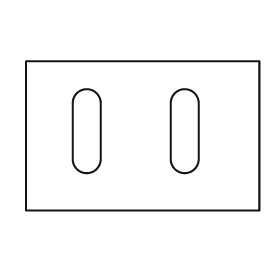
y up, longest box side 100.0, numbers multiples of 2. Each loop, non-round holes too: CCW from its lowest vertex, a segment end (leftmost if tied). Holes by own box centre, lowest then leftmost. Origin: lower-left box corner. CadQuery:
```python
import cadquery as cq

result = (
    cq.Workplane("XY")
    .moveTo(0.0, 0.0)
    .lineTo(100.0, 0.0)
    .lineTo(100.0, 64.0)
    .lineTo(0.0, 64.0)
    .close()
    .moveTo(20.0, 22.0)
    .threePointArc((26.0, 16.0), (32.0, 22.0))
    .lineTo(32.0, 46.0)
    .threePointArc((26.0, 52.0), (20.0, 46.0))
    .close()
    .moveTo(62.0, 22.0)
    .threePointArc((68.0, 16.0), (74.0, 22.0))
    .lineTo(74.0, 46.0)
    .threePointArc((68.0, 52.0), (62.0, 46.0))
    .close()
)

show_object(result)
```